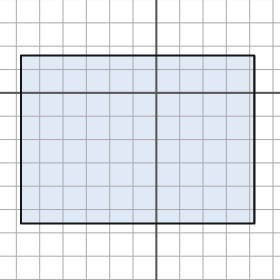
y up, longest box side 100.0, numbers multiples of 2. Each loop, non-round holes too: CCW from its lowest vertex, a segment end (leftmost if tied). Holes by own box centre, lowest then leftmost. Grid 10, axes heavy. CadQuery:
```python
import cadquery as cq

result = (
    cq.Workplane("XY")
    .moveTo(-58.0, -56.0)
    .lineTo(42.0, -56.0)
    .lineTo(42.0, 16.0)
    .lineTo(-58.0, 16.0)
    .close()
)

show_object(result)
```